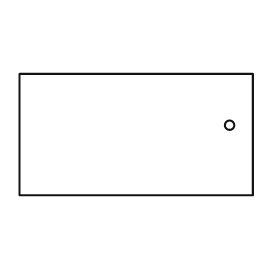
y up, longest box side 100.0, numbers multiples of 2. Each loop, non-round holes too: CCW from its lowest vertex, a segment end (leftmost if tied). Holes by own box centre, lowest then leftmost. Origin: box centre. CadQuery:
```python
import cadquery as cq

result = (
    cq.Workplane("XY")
    .moveTo(-50.0, -26.0)
    .lineTo(50.0, -26.0)
    .lineTo(50.0, 26.0)
    .lineTo(-50.0, 26.0)
    .close()
    .moveTo(40.0, 4.0)
    .circle(2.0)
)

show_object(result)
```